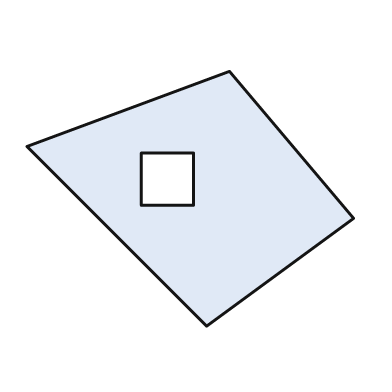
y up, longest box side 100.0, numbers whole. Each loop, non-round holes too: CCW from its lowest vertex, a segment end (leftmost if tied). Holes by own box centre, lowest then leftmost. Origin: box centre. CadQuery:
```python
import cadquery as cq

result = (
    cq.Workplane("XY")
    .moveTo(5.0, -39.0)
    .lineTo(50.0, -6.0)
    .lineTo(12.0, 39.0)
    .lineTo(-50.0, 16.0)
    .close()
    .moveTo(-15.0, -2.0)
    .lineTo(1.0, -2.0)
    .lineTo(1.0, 14.0)
    .lineTo(-15.0, 14.0)
    .close()
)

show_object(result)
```